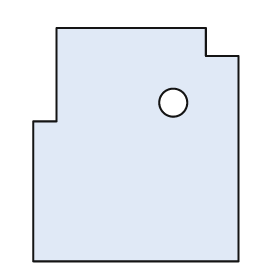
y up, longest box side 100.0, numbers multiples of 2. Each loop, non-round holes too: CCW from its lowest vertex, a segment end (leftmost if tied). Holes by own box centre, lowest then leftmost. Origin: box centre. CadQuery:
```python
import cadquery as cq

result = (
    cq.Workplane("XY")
    .moveTo(-44.0, -50.0)
    .lineTo(44.0, -50.0)
    .lineTo(44.0, 38.0)
    .lineTo(30.0, 38.0)
    .lineTo(30.0, 50.0)
    .lineTo(-34.0, 50.0)
    .lineTo(-34.0, 10.0)
    .lineTo(-44.0, 10.0)
    .close()
    .moveTo(16.0, 18.0)
    .circle(6.0)
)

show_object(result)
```